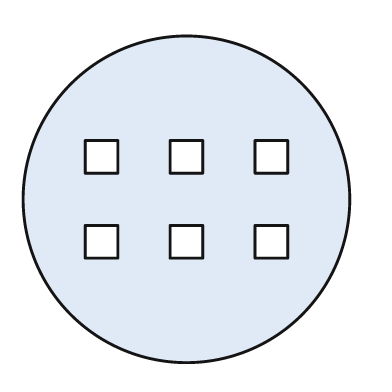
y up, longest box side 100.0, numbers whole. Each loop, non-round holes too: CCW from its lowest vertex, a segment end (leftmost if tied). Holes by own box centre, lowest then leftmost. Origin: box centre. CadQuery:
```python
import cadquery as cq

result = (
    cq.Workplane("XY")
    .moveTo(0.0, 0.0)
    .circle(50.0)
    .moveTo(-31.0, -18.0)
    .lineTo(-21.0, -18.0)
    .lineTo(-21.0, -8.0)
    .lineTo(-31.0, -8.0)
    .close()
    .moveTo(-5.0, -18.0)
    .lineTo(5.0, -18.0)
    .lineTo(5.0, -8.0)
    .lineTo(-5.0, -8.0)
    .close()
    .moveTo(21.0, -18.0)
    .lineTo(31.0, -18.0)
    .lineTo(31.0, -8.0)
    .lineTo(21.0, -8.0)
    .close()
    .moveTo(-31.0, 8.0)
    .lineTo(-21.0, 8.0)
    .lineTo(-21.0, 18.0)
    .lineTo(-31.0, 18.0)
    .close()
    .moveTo(-5.0, 8.0)
    .lineTo(5.0, 8.0)
    .lineTo(5.0, 18.0)
    .lineTo(-5.0, 18.0)
    .close()
    .moveTo(21.0, 8.0)
    .lineTo(31.0, 8.0)
    .lineTo(31.0, 18.0)
    .lineTo(21.0, 18.0)
    .close()
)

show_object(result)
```